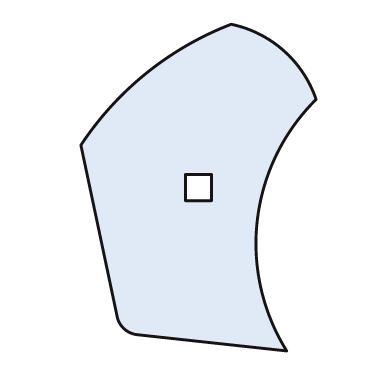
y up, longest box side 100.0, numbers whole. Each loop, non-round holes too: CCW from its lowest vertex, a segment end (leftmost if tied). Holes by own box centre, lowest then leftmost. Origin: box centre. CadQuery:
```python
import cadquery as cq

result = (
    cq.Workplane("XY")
    .moveTo(27.0, -50.0)
    .threePointArc((18.0, -10.0), (36.0, 27.0))
    .threePointArc((26.0, 42.0), (10.0, 50.0))
    .threePointArc((-16.0, 35.0), (-36.0, 13.0))
    .lineTo(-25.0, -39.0)
    .threePointArc((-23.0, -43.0), (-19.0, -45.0))
    .close()
    .moveTo(-4.0, -4.0)
    .lineTo(4.0, -4.0)
    .lineTo(4.0, 4.0)
    .lineTo(-4.0, 4.0)
    .close()
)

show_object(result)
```